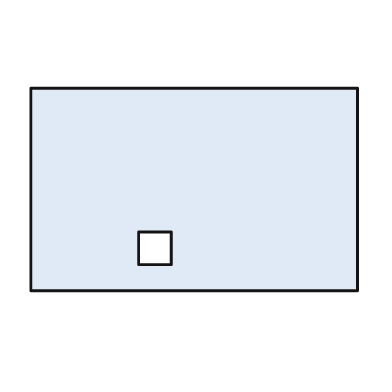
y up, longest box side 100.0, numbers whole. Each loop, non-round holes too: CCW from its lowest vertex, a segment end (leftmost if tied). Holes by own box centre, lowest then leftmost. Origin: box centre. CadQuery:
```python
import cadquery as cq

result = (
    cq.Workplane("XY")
    .moveTo(-50.0, -31.0)
    .lineTo(50.0, -31.0)
    .lineTo(50.0, 31.0)
    .lineTo(-50.0, 31.0)
    .close()
    .moveTo(-17.0, -23.0)
    .lineTo(-7.0, -23.0)
    .lineTo(-7.0, -13.0)
    .lineTo(-17.0, -13.0)
    .close()
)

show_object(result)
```